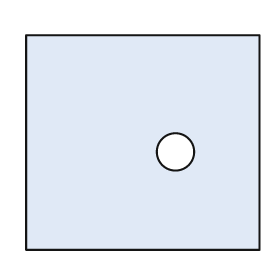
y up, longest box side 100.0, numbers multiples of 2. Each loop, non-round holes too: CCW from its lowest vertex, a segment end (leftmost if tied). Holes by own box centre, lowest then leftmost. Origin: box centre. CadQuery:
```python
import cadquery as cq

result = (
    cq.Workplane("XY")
    .moveTo(-50.0, -46.0)
    .lineTo(50.0, -46.0)
    .lineTo(50.0, 46.0)
    .lineTo(-50.0, 46.0)
    .close()
    .moveTo(14.0, -4.0)
    .circle(8.0)
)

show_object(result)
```